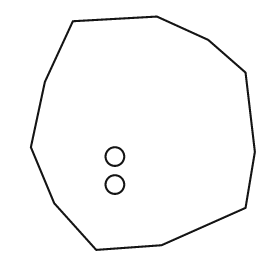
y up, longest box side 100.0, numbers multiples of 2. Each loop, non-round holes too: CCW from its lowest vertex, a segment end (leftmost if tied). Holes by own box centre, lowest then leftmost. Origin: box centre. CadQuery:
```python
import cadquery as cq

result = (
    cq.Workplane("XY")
    .moveTo(-20.0, -50.0)
    .lineTo(8.0, -48.0)
    .lineTo(44.0, -32.0)
    .lineTo(48.0, -8.0)
    .lineTo(44.0, 26.0)
    .lineTo(28.0, 40.0)
    .lineTo(6.0, 50.0)
    .lineTo(-30.0, 48.0)
    .lineTo(-42.0, 22.0)
    .lineTo(-48.0, -6.0)
    .lineTo(-38.0, -30.0)
    .close()
    .moveTo(-12.0, -22.0)
    .circle(4.0)
    .moveTo(-12.0, -10.0)
    .circle(4.0)
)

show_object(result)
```